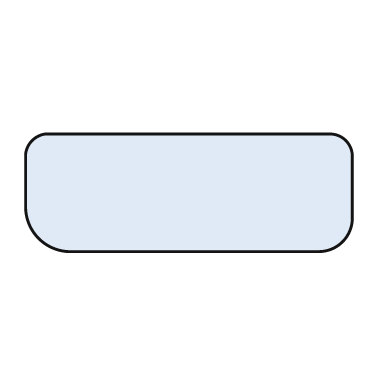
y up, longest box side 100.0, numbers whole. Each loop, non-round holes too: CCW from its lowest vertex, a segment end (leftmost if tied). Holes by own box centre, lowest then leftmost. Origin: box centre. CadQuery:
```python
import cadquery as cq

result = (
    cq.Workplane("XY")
    .moveTo(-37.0, -18.0)
    .lineTo(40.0, -18.0)
    .threePointArc((47.0, -15.0), (50.0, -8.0))
    .lineTo(50.0, 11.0)
    .threePointArc((48.0, 16.0), (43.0, 18.0))
    .lineTo(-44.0, 18.0)
    .threePointArc((-48.0, 16.0), (-50.0, 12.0))
    .lineTo(-50.0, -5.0)
    .threePointArc((-46.0, -14.0), (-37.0, -18.0))
    .close()
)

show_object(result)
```